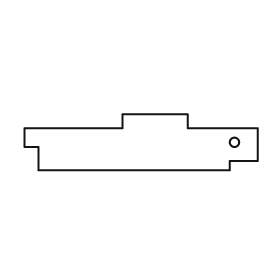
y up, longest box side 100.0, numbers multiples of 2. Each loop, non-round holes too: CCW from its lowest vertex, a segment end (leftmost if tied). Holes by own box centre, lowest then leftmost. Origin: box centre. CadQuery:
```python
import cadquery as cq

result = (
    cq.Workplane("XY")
    .moveTo(-44.0, -12.0)
    .lineTo(38.0, -12.0)
    .lineTo(38.0, -8.0)
    .lineTo(50.0, -8.0)
    .lineTo(50.0, 6.0)
    .lineTo(20.0, 6.0)
    .lineTo(20.0, 12.0)
    .lineTo(-8.0, 12.0)
    .lineTo(-8.0, 6.0)
    .lineTo(-50.0, 6.0)
    .lineTo(-50.0, -2.0)
    .lineTo(-44.0, -2.0)
    .close()
    .moveTo(40.0, 0.0)
    .circle(2.0)
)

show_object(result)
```